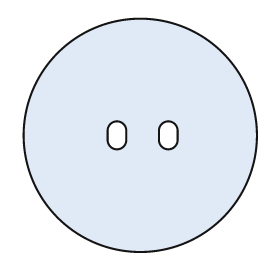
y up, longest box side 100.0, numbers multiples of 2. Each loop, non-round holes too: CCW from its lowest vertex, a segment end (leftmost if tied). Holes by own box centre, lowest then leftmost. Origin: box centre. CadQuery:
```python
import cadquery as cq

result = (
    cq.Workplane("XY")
    .moveTo(0.0, 0.0)
    .circle(50.0)
    .moveTo(-14.0, -2.0)
    .threePointArc((-10.0, -6.0), (-6.0, -2.0))
    .lineTo(-6.0, 2.0)
    .threePointArc((-10.0, 6.0), (-14.0, 2.0))
    .close()
    .moveTo(8.0, -2.0)
    .threePointArc((12.0, -6.0), (16.0, -2.0))
    .lineTo(16.0, 2.0)
    .threePointArc((12.0, 6.0), (8.0, 2.0))
    .close()
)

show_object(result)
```